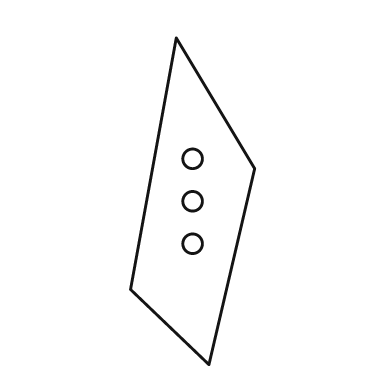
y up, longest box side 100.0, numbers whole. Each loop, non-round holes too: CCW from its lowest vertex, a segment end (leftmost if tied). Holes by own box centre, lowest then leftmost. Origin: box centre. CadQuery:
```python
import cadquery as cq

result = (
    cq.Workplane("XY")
    .moveTo(5.0, -50.0)
    .lineTo(19.0, 10.0)
    .lineTo(-5.0, 50.0)
    .lineTo(-19.0, -27.0)
    .close()
    .moveTo(0.0, -13.0)
    .circle(3.0)
    .moveTo(0.0, 0.0)
    .circle(3.0)
    .moveTo(0.0, 13.0)
    .circle(3.0)
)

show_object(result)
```